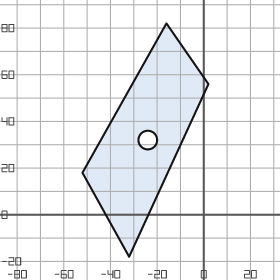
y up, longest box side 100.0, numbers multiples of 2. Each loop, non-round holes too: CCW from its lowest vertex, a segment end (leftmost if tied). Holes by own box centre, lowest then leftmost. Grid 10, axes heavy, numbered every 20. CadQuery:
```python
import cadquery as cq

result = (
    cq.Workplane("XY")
    .moveTo(-32.0, -18.0)
    .lineTo(2.0, 56.0)
    .lineTo(-16.0, 82.0)
    .lineTo(-52.0, 18.0)
    .close()
    .moveTo(-24.0, 32.0)
    .circle(4.0)
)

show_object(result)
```